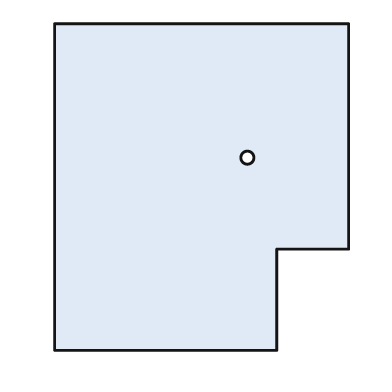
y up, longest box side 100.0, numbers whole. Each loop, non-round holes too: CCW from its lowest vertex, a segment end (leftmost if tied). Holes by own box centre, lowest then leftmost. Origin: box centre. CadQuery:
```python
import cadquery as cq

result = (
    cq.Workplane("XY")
    .moveTo(-45.0, -50.0)
    .lineTo(23.0, -50.0)
    .lineTo(23.0, -19.0)
    .lineTo(45.0, -19.0)
    .lineTo(45.0, 50.0)
    .lineTo(-45.0, 50.0)
    .close()
    .moveTo(14.0, 9.0)
    .circle(2.0)
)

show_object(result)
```